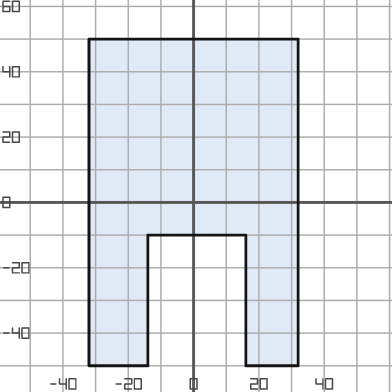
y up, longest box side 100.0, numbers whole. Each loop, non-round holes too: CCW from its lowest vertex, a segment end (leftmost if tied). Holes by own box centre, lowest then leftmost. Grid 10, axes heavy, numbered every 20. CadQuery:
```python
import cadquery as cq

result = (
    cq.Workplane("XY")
    .moveTo(-32.0, -50.0)
    .lineTo(-14.0, -50.0)
    .lineTo(-14.0, -10.0)
    .lineTo(16.0, -10.0)
    .lineTo(16.0, -50.0)
    .lineTo(32.0, -50.0)
    .lineTo(32.0, 50.0)
    .lineTo(-32.0, 50.0)
    .close()
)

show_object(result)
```